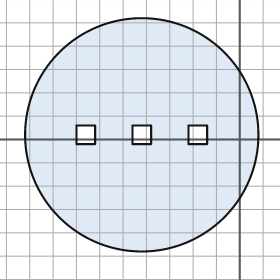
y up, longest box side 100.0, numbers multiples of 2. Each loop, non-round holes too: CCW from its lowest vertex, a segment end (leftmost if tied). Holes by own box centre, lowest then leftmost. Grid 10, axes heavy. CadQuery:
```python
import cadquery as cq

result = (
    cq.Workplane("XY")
    .moveTo(-42.0, 2.0)
    .circle(50.0)
    .moveTo(-70.0, -2.0)
    .lineTo(-62.0, -2.0)
    .lineTo(-62.0, 6.0)
    .lineTo(-70.0, 6.0)
    .close()
    .moveTo(-46.0, -2.0)
    .lineTo(-38.0, -2.0)
    .lineTo(-38.0, 6.0)
    .lineTo(-46.0, 6.0)
    .close()
    .moveTo(-22.0, -2.0)
    .lineTo(-14.0, -2.0)
    .lineTo(-14.0, 6.0)
    .lineTo(-22.0, 6.0)
    .close()
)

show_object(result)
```